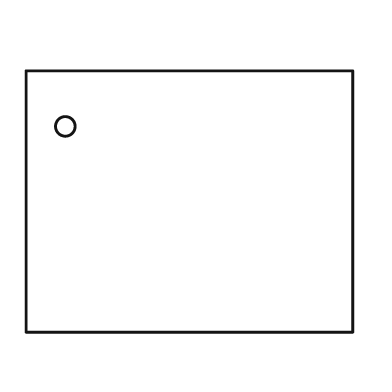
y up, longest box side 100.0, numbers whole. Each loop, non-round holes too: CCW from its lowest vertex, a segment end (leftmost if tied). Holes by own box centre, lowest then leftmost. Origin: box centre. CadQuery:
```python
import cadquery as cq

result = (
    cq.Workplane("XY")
    .moveTo(-50.0, -40.0)
    .lineTo(50.0, -40.0)
    .lineTo(50.0, 40.0)
    .lineTo(-50.0, 40.0)
    .close()
    .moveTo(-38.0, 23.0)
    .circle(3.0)
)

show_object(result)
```